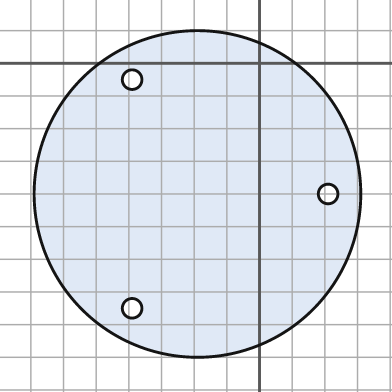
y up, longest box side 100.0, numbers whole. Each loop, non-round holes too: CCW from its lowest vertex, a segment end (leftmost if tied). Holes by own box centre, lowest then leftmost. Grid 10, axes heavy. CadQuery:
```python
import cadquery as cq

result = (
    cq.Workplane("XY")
    .moveTo(-19.0, -40.0)
    .circle(50.0)
    .moveTo(-39.0, -75.0)
    .circle(3.0)
    .moveTo(21.0, -40.0)
    .circle(3.0)
    .moveTo(-39.0, -5.0)
    .circle(3.0)
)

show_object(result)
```